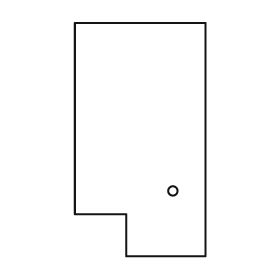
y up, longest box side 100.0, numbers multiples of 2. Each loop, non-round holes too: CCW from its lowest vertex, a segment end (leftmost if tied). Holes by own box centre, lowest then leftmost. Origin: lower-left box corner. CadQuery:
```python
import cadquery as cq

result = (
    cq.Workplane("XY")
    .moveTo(22.0, 0.0)
    .lineTo(56.0, 0.0)
    .lineTo(56.0, 100.0)
    .lineTo(0.0, 100.0)
    .lineTo(0.0, 18.0)
    .lineTo(22.0, 18.0)
    .close()
    .moveTo(42.0, 28.0)
    .circle(2.0)
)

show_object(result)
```